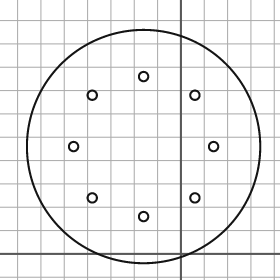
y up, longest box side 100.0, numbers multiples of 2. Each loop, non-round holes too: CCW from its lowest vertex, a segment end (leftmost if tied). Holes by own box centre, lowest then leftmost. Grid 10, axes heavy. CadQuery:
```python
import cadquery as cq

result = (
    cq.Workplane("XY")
    .moveTo(-16.0, 46.0)
    .circle(50.0)
    .moveTo(-16.0, 16.0)
    .circle(2.0)
    .moveTo(-38.0, 24.0)
    .circle(2.0)
    .moveTo(6.0, 24.0)
    .circle(2.0)
    .moveTo(-46.0, 46.0)
    .circle(2.0)
    .moveTo(14.0, 46.0)
    .circle(2.0)
    .moveTo(-38.0, 68.0)
    .circle(2.0)
    .moveTo(6.0, 68.0)
    .circle(2.0)
    .moveTo(-16.0, 76.0)
    .circle(2.0)
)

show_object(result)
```